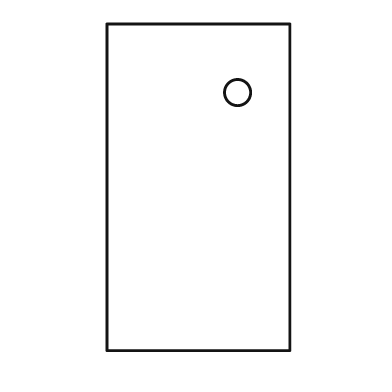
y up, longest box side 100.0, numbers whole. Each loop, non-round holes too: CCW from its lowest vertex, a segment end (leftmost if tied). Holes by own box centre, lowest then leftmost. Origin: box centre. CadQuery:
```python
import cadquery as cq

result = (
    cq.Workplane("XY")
    .moveTo(-28.0, -50.0)
    .lineTo(28.0, -50.0)
    .lineTo(28.0, 50.0)
    .lineTo(-28.0, 50.0)
    .close()
    .moveTo(12.0, 29.0)
    .circle(4.0)
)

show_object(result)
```